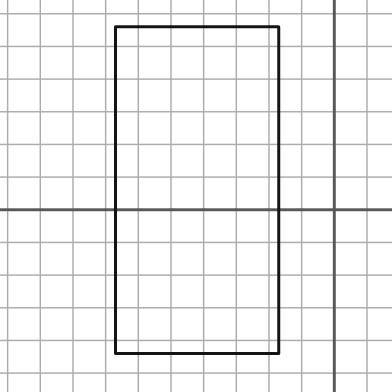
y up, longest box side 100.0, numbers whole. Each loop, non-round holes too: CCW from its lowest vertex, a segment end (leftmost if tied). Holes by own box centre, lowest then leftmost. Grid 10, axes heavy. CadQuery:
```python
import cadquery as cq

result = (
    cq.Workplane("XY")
    .moveTo(-67.0, -44.0)
    .lineTo(-17.0, -44.0)
    .lineTo(-17.0, 56.0)
    .lineTo(-67.0, 56.0)
    .close()
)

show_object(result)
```